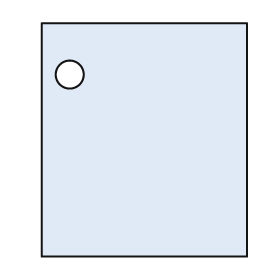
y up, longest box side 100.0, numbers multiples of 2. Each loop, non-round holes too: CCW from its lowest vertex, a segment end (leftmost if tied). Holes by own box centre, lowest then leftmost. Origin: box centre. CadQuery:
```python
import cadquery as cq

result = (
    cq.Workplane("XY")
    .moveTo(-44.0, -50.0)
    .lineTo(44.0, -50.0)
    .lineTo(44.0, 50.0)
    .lineTo(-44.0, 50.0)
    .close()
    .moveTo(-32.0, 28.0)
    .circle(6.0)
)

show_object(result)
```